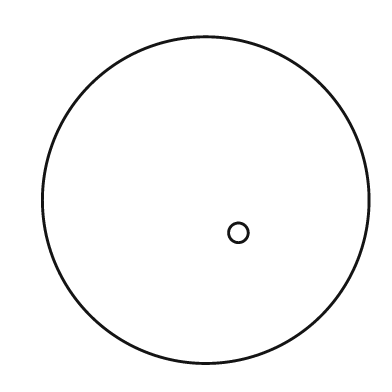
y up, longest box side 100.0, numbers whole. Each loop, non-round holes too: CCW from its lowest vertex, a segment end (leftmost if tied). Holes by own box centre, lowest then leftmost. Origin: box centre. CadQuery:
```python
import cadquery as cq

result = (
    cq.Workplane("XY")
    .moveTo(0.0, 0.0)
    .circle(50.0)
    .moveTo(10.0, -10.0)
    .circle(3.0)
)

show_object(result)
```